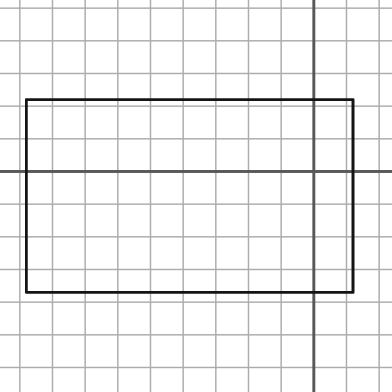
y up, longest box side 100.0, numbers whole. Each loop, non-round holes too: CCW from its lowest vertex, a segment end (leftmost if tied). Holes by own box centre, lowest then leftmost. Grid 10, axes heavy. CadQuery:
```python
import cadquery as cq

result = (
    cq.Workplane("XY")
    .moveTo(-88.0, -37.0)
    .lineTo(12.0, -37.0)
    .lineTo(12.0, 22.0)
    .lineTo(-88.0, 22.0)
    .close()
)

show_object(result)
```